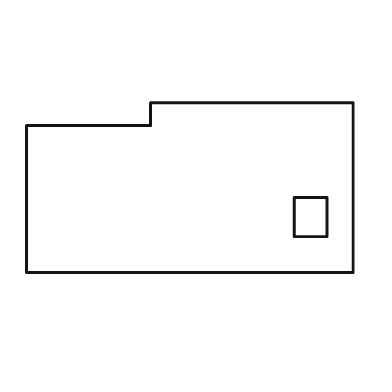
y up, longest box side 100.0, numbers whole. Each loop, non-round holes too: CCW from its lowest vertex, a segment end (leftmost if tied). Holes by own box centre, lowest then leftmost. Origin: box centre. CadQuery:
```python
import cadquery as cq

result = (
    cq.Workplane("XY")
    .moveTo(-50.0, -26.0)
    .lineTo(50.0, -26.0)
    .lineTo(50.0, 26.0)
    .lineTo(-12.0, 26.0)
    .lineTo(-12.0, 19.0)
    .lineTo(-50.0, 19.0)
    .close()
    .moveTo(32.0, -15.0)
    .lineTo(42.0, -15.0)
    .lineTo(42.0, -3.0)
    .lineTo(32.0, -3.0)
    .close()
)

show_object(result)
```